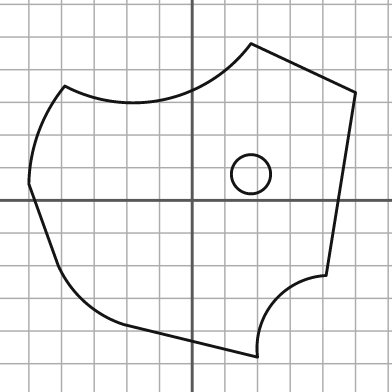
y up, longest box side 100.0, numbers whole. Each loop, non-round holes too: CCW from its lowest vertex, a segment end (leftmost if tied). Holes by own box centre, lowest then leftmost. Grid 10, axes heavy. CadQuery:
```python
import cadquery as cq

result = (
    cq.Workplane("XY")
    .moveTo(20.0, -48.0)
    .threePointArc((25.0, -31.0), (41.0, -23.0))
    .lineTo(50.0, 33.0)
    .lineTo(18.0, 48.0)
    .threePointArc((-8.0, 31.0), (-39.0, 35.0))
    .threePointArc((-47.0, 21.0), (-50.0, 5.0))
    .lineTo(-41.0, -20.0)
    .threePointArc((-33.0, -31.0), (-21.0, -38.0))
    .close()
    .moveTo(18.0, 8.0)
    .circle(6.0)
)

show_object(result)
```